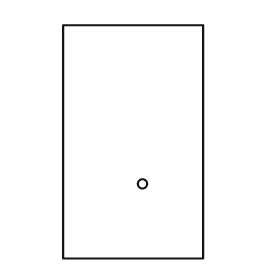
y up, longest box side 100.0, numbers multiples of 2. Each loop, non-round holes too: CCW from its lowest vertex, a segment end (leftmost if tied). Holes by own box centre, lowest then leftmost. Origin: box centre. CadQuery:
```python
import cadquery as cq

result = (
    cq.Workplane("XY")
    .moveTo(-30.0, -50.0)
    .lineTo(30.0, -50.0)
    .lineTo(30.0, 50.0)
    .lineTo(-30.0, 50.0)
    .close()
    .moveTo(4.0, -18.0)
    .circle(2.0)
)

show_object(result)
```